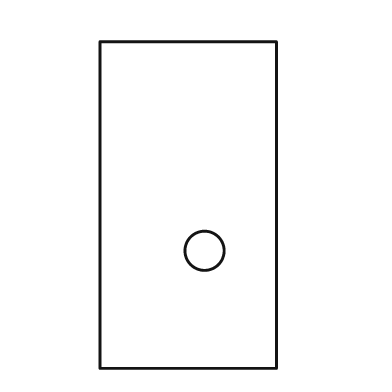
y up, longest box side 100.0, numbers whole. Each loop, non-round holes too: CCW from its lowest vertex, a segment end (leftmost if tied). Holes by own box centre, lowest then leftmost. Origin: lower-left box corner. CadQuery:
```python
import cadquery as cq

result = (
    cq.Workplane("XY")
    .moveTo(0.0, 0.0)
    .lineTo(54.0, 0.0)
    .lineTo(54.0, 100.0)
    .lineTo(0.0, 100.0)
    .close()
    .moveTo(32.0, 36.0)
    .circle(6.0)
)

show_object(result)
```